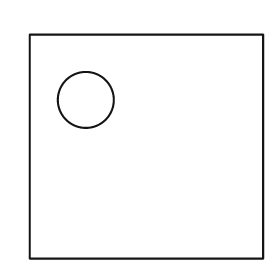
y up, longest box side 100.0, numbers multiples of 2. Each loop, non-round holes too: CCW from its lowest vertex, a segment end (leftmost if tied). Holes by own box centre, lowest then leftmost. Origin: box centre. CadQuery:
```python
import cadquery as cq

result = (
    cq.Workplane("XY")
    .moveTo(-50.0, -48.0)
    .lineTo(50.0, -48.0)
    .lineTo(50.0, 48.0)
    .lineTo(-50.0, 48.0)
    .close()
    .moveTo(-26.0, 20.0)
    .circle(12.0)
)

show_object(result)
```